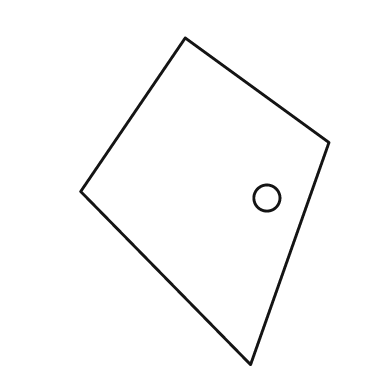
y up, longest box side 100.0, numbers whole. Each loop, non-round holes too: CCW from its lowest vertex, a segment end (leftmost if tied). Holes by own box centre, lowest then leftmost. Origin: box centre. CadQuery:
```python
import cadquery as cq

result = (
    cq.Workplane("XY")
    .moveTo(14.0, -50.0)
    .lineTo(38.0, 18.0)
    .lineTo(-6.0, 50.0)
    .lineTo(-38.0, 3.0)
    .close()
    .moveTo(19.0, 1.0)
    .circle(4.0)
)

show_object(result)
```